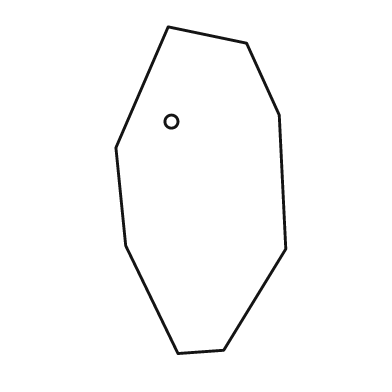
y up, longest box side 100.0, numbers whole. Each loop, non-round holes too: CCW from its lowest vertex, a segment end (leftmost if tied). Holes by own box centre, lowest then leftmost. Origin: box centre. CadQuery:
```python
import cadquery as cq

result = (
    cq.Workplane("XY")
    .moveTo(-7.0, -50.0)
    .lineTo(7.0, -49.0)
    .lineTo(26.0, -18.0)
    .lineTo(24.0, 23.0)
    .lineTo(14.0, 45.0)
    .lineTo(-10.0, 50.0)
    .lineTo(-26.0, 13.0)
    .lineTo(-23.0, -17.0)
    .close()
    .moveTo(-9.0, 21.0)
    .circle(2.0)
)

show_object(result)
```